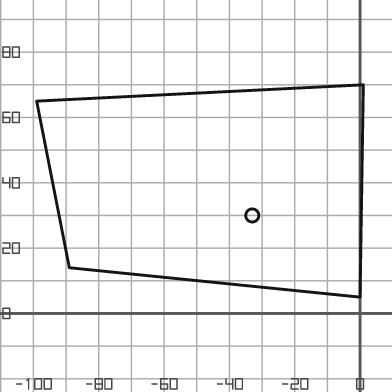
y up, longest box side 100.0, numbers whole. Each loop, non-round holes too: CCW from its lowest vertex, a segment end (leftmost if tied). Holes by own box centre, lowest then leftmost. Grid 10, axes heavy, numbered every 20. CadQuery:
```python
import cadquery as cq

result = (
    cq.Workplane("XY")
    .moveTo(0.0, 5.0)
    .lineTo(1.0, 70.0)
    .lineTo(-99.0, 65.0)
    .lineTo(-89.0, 14.0)
    .close()
    .moveTo(-33.0, 30.0)
    .circle(2.0)
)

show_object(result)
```